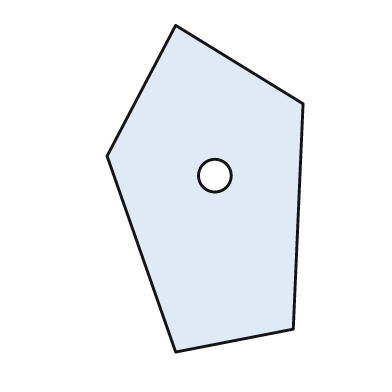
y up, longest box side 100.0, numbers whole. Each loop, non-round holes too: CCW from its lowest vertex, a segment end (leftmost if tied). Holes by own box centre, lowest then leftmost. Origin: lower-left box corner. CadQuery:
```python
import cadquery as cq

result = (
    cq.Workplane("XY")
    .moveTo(21.0, 0.0)
    .lineTo(57.0, 7.0)
    .lineTo(60.0, 76.0)
    .lineTo(21.0, 100.0)
    .lineTo(0.0, 60.0)
    .close()
    .moveTo(33.0, 54.0)
    .circle(5.0)
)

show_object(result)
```